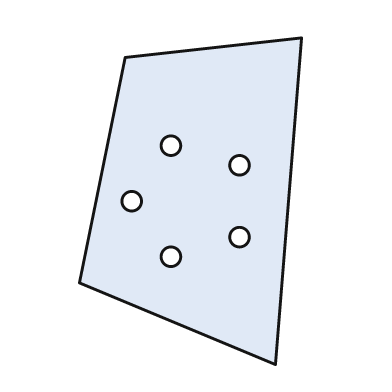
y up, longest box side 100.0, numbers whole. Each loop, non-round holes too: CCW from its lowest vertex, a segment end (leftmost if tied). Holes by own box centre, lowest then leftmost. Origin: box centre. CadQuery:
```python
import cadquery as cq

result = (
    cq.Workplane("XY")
    .moveTo(26.0, -50.0)
    .lineTo(34.0, 50.0)
    .lineTo(-20.0, 44.0)
    .lineTo(-34.0, -25.0)
    .close()
    .moveTo(-6.0, -17.0)
    .circle(3.0)
    .moveTo(15.0, -11.0)
    .circle(3.0)
    .moveTo(-18.0, 0.0)
    .circle(3.0)
    .moveTo(15.0, 11.0)
    .circle(3.0)
    .moveTo(-6.0, 17.0)
    .circle(3.0)
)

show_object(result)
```